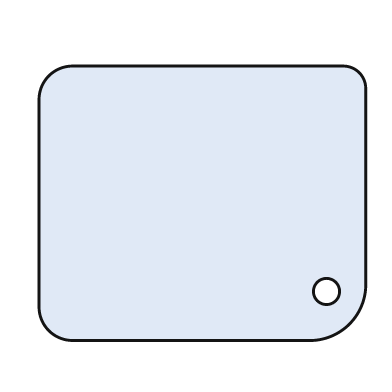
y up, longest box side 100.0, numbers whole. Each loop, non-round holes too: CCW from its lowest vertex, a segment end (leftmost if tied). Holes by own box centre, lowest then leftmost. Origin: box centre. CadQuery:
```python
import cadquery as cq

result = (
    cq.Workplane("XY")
    .moveTo(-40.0, -42.0)
    .lineTo(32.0, -42.0)
    .threePointArc((45.0, -37.0), (50.0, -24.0))
    .lineTo(50.0, 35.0)
    .threePointArc((48.0, 40.0), (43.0, 42.0))
    .lineTo(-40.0, 42.0)
    .threePointArc((-47.0, 39.0), (-50.0, 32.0))
    .lineTo(-50.0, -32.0)
    .threePointArc((-47.0, -39.0), (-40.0, -42.0))
    .close()
    .moveTo(38.0, -27.0)
    .circle(4.0)
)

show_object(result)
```